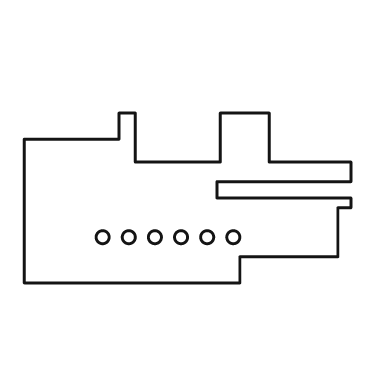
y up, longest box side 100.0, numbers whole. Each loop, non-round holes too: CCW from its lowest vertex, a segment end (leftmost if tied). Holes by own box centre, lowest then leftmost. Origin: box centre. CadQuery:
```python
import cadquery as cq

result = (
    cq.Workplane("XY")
    .moveTo(-50.0, -26.0)
    .lineTo(16.0, -26.0)
    .lineTo(16.0, -18.0)
    .lineTo(46.0, -18.0)
    .lineTo(46.0, -3.0)
    .lineTo(50.0, -3.0)
    .lineTo(50.0, 0.0)
    .lineTo(9.0, 0.0)
    .lineTo(9.0, 5.0)
    .lineTo(50.0, 5.0)
    .lineTo(50.0, 11.0)
    .lineTo(25.0, 11.0)
    .lineTo(25.0, 26.0)
    .lineTo(10.0, 26.0)
    .lineTo(10.0, 11.0)
    .lineTo(-16.0, 11.0)
    .lineTo(-16.0, 26.0)
    .lineTo(-21.0, 26.0)
    .lineTo(-21.0, 18.0)
    .lineTo(-50.0, 18.0)
    .close()
    .moveTo(-26.0, -12.0)
    .circle(2.0)
    .moveTo(-18.0, -12.0)
    .circle(2.0)
    .moveTo(-10.0, -12.0)
    .circle(2.0)
    .moveTo(-2.0, -12.0)
    .circle(2.0)
    .moveTo(6.0, -12.0)
    .circle(2.0)
    .moveTo(14.0, -12.0)
    .circle(2.0)
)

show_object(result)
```